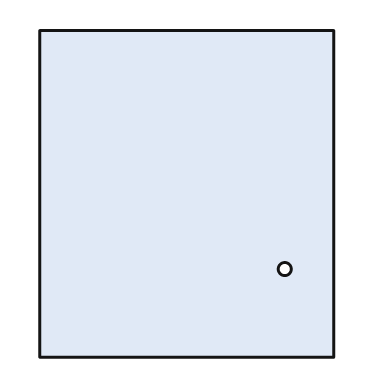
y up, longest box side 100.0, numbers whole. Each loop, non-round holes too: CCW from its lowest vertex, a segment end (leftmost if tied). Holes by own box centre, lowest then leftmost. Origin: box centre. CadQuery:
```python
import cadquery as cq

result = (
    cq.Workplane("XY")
    .moveTo(-45.0, -50.0)
    .lineTo(45.0, -50.0)
    .lineTo(45.0, 50.0)
    .lineTo(-45.0, 50.0)
    .close()
    .moveTo(30.0, -23.0)
    .circle(2.0)
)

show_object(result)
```